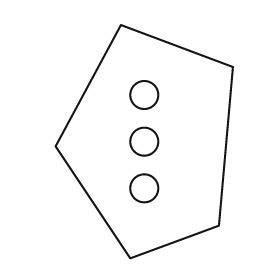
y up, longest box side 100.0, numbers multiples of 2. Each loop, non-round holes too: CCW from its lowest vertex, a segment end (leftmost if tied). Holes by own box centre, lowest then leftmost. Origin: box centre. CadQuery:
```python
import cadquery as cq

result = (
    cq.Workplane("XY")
    .moveTo(-6.0, -50.0)
    .lineTo(32.0, -36.0)
    .lineTo(38.0, 32.0)
    .lineTo(-10.0, 50.0)
    .lineTo(-38.0, -2.0)
    .close()
    .moveTo(0.0, -20.0)
    .circle(6.0)
    .moveTo(0.0, 0.0)
    .circle(6.0)
    .moveTo(0.0, 20.0)
    .circle(6.0)
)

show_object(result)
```